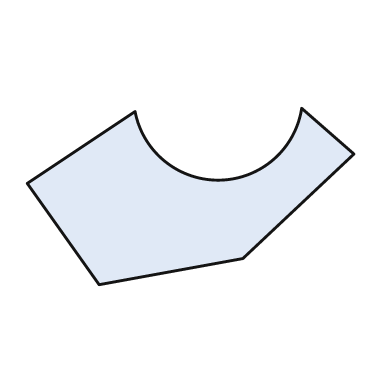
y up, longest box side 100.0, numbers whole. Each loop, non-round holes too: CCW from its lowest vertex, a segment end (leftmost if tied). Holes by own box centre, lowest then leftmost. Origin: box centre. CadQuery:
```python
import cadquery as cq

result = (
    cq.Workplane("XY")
    .moveTo(-28.0, -27.0)
    .lineTo(16.0, -19.0)
    .lineTo(50.0, 13.0)
    .lineTo(34.0, 27.0)
    .threePointArc((9.0, 5.0), (-17.0, 26.0))
    .lineTo(-50.0, 4.0)
    .close()
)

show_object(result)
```